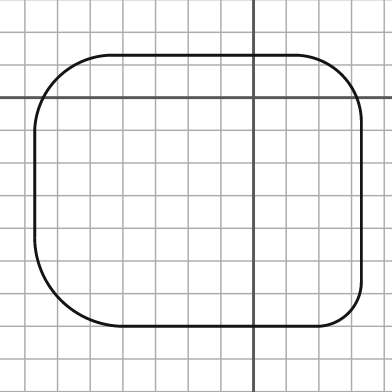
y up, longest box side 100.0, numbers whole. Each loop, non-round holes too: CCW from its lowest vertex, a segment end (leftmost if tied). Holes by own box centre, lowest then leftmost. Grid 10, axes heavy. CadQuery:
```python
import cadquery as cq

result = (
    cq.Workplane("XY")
    .moveTo(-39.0, -70.0)
    .lineTo(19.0, -70.0)
    .threePointArc((29.0, -66.0), (33.0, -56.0))
    .lineTo(33.0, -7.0)
    .threePointArc((27.0, 7.0), (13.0, 13.0))
    .lineTo(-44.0, 13.0)
    .threePointArc((-60.0, 6.0), (-67.0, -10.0))
    .lineTo(-67.0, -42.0)
    .threePointArc((-59.0, -62.0), (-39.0, -70.0))
    .close()
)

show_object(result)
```